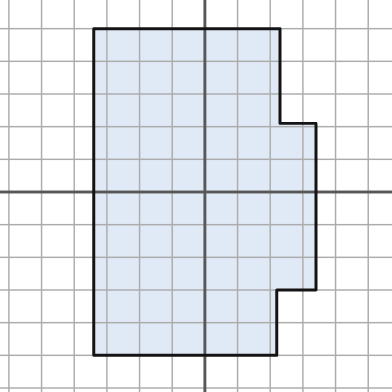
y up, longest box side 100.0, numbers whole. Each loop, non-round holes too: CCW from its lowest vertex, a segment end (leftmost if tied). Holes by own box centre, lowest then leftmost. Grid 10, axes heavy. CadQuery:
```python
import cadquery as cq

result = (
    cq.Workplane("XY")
    .moveTo(-34.0, -50.0)
    .lineTo(22.0, -50.0)
    .lineTo(22.0, -30.0)
    .lineTo(34.0, -30.0)
    .lineTo(34.0, 21.0)
    .lineTo(23.0, 21.0)
    .lineTo(23.0, 50.0)
    .lineTo(-34.0, 50.0)
    .close()
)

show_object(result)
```